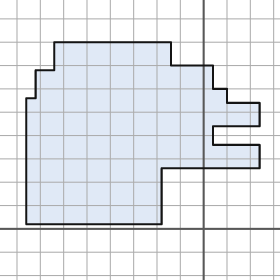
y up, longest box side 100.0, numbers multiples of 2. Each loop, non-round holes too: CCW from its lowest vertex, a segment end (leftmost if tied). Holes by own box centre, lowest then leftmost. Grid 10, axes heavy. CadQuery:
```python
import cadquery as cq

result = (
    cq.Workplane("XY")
    .moveTo(-76.0, 2.0)
    .lineTo(-18.0, 2.0)
    .lineTo(-18.0, 26.0)
    .lineTo(24.0, 26.0)
    .lineTo(24.0, 36.0)
    .lineTo(4.0, 36.0)
    .lineTo(4.0, 44.0)
    .lineTo(24.0, 44.0)
    .lineTo(24.0, 54.0)
    .lineTo(10.0, 54.0)
    .lineTo(10.0, 60.0)
    .lineTo(4.0, 60.0)
    .lineTo(4.0, 70.0)
    .lineTo(-14.0, 70.0)
    .lineTo(-14.0, 80.0)
    .lineTo(-64.0, 80.0)
    .lineTo(-64.0, 68.0)
    .lineTo(-72.0, 68.0)
    .lineTo(-72.0, 56.0)
    .lineTo(-76.0, 56.0)
    .close()
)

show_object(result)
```